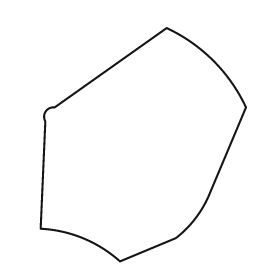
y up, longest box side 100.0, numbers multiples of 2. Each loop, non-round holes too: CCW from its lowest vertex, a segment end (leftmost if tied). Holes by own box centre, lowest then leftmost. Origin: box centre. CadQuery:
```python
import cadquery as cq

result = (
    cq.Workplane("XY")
    .moveTo(-10.0, -50.0)
    .lineTo(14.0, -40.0)
    .threePointArc((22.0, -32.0), (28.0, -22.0))
    .lineTo(44.0, 16.0)
    .threePointArc((30.0, 36.0), (10.0, 50.0))
    .lineTo(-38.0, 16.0)
    .threePointArc((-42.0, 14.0), (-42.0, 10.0))
    .lineTo(-44.0, -36.0)
    .threePointArc((-26.0, -40.0), (-10.0, -50.0))
    .close()
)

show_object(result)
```